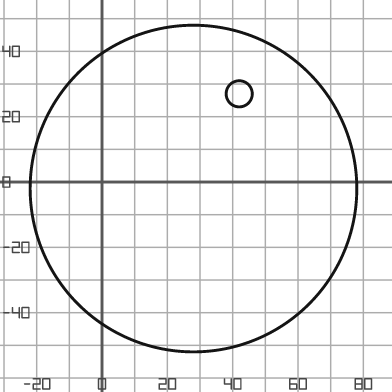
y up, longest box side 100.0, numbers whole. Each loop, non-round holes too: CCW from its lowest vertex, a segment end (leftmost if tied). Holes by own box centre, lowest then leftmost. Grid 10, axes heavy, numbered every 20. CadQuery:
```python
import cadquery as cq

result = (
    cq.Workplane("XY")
    .moveTo(28.0, -2.0)
    .circle(50.0)
    .moveTo(42.0, 27.0)
    .circle(4.0)
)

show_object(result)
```